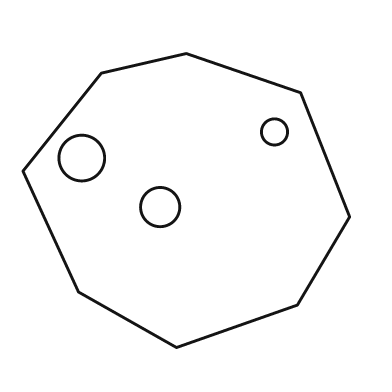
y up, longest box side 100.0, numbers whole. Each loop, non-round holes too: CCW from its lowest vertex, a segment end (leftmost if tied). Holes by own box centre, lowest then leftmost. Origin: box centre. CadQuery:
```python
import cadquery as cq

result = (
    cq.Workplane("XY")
    .moveTo(-3.0, -45.0)
    .lineTo(34.0, -32.0)
    .lineTo(50.0, -5.0)
    .lineTo(35.0, 33.0)
    .lineTo(0.0, 45.0)
    .lineTo(-26.0, 39.0)
    .lineTo(-50.0, 9.0)
    .lineTo(-33.0, -28.0)
    .close()
    .moveTo(-8.0, -2.0)
    .circle(6.0)
    .moveTo(-32.0, 13.0)
    .circle(7.0)
    .moveTo(27.0, 21.0)
    .circle(4.0)
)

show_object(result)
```